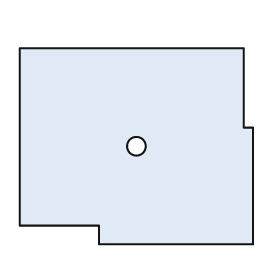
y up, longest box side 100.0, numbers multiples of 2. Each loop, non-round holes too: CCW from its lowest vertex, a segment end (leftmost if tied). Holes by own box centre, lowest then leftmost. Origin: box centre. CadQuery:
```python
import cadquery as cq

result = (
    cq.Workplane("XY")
    .moveTo(-16.0, -42.0)
    .lineTo(50.0, -42.0)
    .lineTo(50.0, 8.0)
    .lineTo(46.0, 8.0)
    .lineTo(46.0, 42.0)
    .lineTo(-50.0, 42.0)
    .lineTo(-50.0, -34.0)
    .lineTo(-16.0, -34.0)
    .close()
    .moveTo(0.0, 0.0)
    .circle(4.0)
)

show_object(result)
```